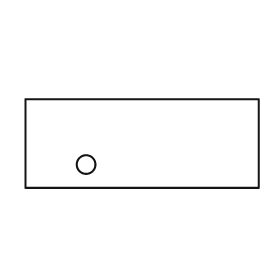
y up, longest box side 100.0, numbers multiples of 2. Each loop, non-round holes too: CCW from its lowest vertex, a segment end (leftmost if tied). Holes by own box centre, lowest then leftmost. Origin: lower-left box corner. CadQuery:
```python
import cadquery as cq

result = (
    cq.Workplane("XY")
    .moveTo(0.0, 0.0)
    .lineTo(100.0, 0.0)
    .lineTo(100.0, 38.0)
    .lineTo(0.0, 38.0)
    .close()
    .moveTo(26.0, 10.0)
    .circle(4.0)
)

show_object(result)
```